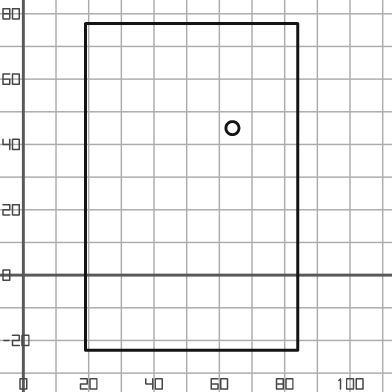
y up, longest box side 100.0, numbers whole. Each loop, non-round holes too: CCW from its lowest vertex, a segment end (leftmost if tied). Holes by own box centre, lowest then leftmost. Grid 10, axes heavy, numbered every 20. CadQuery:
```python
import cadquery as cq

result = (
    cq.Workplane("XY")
    .moveTo(19.0, -23.0)
    .lineTo(84.0, -23.0)
    .lineTo(84.0, 77.0)
    .lineTo(19.0, 77.0)
    .close()
    .moveTo(64.0, 45.0)
    .circle(2.0)
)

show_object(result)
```